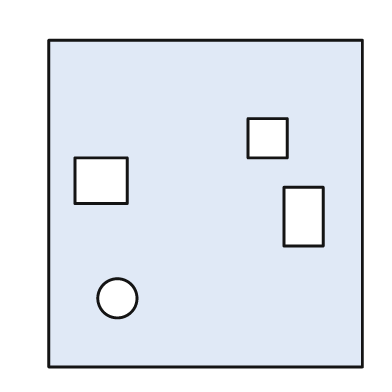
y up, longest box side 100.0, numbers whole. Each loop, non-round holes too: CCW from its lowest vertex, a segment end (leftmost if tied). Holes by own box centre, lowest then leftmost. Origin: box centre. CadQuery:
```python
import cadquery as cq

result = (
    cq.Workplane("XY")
    .moveTo(-48.0, -50.0)
    .lineTo(48.0, -50.0)
    .lineTo(48.0, 50.0)
    .lineTo(-48.0, 50.0)
    .close()
    .moveTo(-27.0, -29.0)
    .circle(6.0)
    .moveTo(24.0, -13.0)
    .lineTo(36.0, -13.0)
    .lineTo(36.0, 5.0)
    .lineTo(24.0, 5.0)
    .close()
    .moveTo(-40.0, 0.0)
    .lineTo(-24.0, 0.0)
    .lineTo(-24.0, 14.0)
    .lineTo(-40.0, 14.0)
    .close()
    .moveTo(13.0, 14.0)
    .lineTo(25.0, 14.0)
    .lineTo(25.0, 26.0)
    .lineTo(13.0, 26.0)
    .close()
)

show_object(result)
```